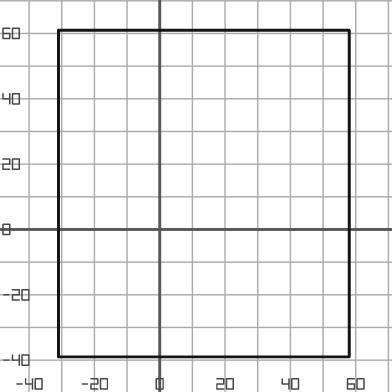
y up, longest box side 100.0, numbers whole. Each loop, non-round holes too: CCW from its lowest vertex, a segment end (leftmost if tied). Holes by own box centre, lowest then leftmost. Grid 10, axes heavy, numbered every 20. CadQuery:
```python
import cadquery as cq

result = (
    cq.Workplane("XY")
    .moveTo(-31.0, -39.0)
    .lineTo(58.0, -39.0)
    .lineTo(58.0, 61.0)
    .lineTo(-31.0, 61.0)
    .close()
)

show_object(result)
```